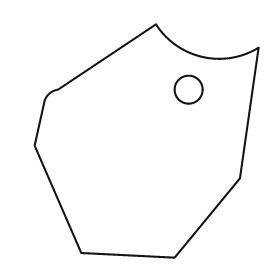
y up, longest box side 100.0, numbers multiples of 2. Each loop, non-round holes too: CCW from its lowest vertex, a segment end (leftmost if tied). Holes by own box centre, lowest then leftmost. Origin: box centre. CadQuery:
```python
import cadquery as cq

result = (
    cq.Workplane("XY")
    .moveTo(12.0, -50.0)
    .lineTo(40.0, -16.0)
    .lineTo(48.0, 40.0)
    .threePointArc((24.0, 36.0), (4.0, 50.0))
    .lineTo(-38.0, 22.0)
    .threePointArc((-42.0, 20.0), (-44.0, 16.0))
    .lineTo(-48.0, -2.0)
    .lineTo(-28.0, -48.0)
    .close()
    .moveTo(18.0, 22.0)
    .circle(6.0)
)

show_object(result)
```